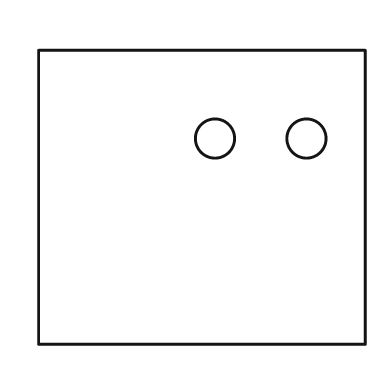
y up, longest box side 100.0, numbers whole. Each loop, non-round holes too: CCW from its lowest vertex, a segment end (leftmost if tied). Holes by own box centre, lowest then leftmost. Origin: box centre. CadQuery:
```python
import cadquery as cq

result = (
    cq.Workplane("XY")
    .moveTo(-50.0, -45.0)
    .lineTo(50.0, -45.0)
    .lineTo(50.0, 45.0)
    .lineTo(-50.0, 45.0)
    .close()
    .moveTo(4.0, 18.0)
    .circle(6.0)
    .moveTo(32.0, 18.0)
    .circle(6.0)
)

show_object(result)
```